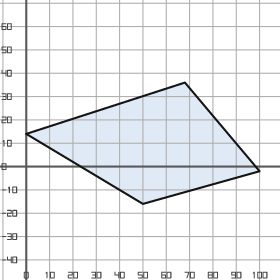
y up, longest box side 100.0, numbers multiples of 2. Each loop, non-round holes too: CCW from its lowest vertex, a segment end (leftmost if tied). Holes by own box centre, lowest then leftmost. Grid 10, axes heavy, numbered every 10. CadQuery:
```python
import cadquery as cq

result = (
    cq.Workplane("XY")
    .moveTo(50.0, -16.0)
    .lineTo(100.0, -2.0)
    .lineTo(68.0, 36.0)
    .lineTo(0.0, 14.0)
    .close()
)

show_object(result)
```